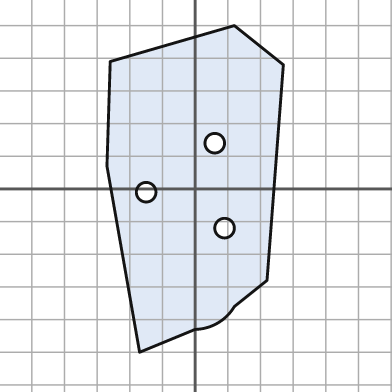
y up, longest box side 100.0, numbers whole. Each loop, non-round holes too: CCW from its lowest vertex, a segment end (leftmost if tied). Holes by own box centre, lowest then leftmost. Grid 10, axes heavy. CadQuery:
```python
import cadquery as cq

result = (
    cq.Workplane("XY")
    .moveTo(-17.0, -50.0)
    .lineTo(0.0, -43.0)
    .threePointArc((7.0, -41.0), (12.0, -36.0))
    .lineTo(22.0, -28.0)
    .lineTo(27.0, 38.0)
    .lineTo(12.0, 50.0)
    .lineTo(-26.0, 39.0)
    .lineTo(-27.0, 7.0)
    .close()
    .moveTo(9.0, -12.0)
    .circle(3.0)
    .moveTo(-15.0, -1.0)
    .circle(3.0)
    .moveTo(6.0, 14.0)
    .circle(3.0)
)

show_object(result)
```